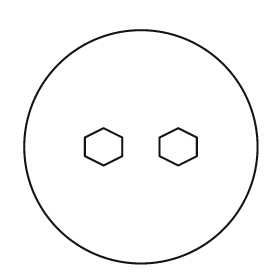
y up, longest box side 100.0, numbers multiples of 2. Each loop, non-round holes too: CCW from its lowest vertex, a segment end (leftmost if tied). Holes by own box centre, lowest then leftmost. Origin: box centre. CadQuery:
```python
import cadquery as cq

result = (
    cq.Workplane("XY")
    .moveTo(0.0, 0.0)
    .circle(50.0)
    .moveTo(-16.0, -8.0)
    .lineTo(-8.0, -4.0)
    .lineTo(-8.0, 4.0)
    .lineTo(-16.0, 8.0)
    .lineTo(-24.0, 4.0)
    .lineTo(-24.0, -4.0)
    .close()
    .moveTo(16.0, -8.0)
    .lineTo(24.0, -4.0)
    .lineTo(24.0, 4.0)
    .lineTo(16.0, 8.0)
    .lineTo(8.0, 4.0)
    .lineTo(8.0, -4.0)
    .close()
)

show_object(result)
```